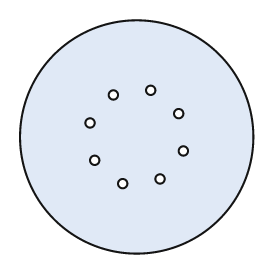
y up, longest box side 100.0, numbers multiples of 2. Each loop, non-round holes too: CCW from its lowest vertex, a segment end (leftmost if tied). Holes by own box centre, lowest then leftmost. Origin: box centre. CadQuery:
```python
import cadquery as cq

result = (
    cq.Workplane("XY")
    .moveTo(0.0, 0.0)
    .circle(50.0)
    .moveTo(-6.0, -20.0)
    .circle(2.0)
    .moveTo(10.0, -18.0)
    .circle(2.0)
    .moveTo(-18.0, -10.0)
    .circle(2.0)
    .moveTo(20.0, -6.0)
    .circle(2.0)
    .moveTo(-20.0, 6.0)
    .circle(2.0)
    .moveTo(18.0, 10.0)
    .circle(2.0)
    .moveTo(-10.0, 18.0)
    .circle(2.0)
    .moveTo(6.0, 20.0)
    .circle(2.0)
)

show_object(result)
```